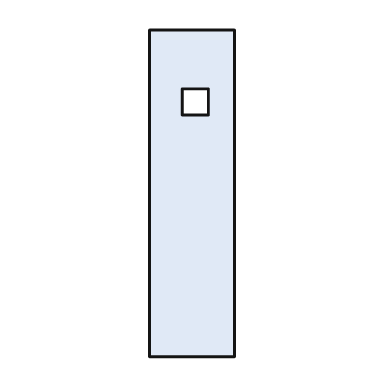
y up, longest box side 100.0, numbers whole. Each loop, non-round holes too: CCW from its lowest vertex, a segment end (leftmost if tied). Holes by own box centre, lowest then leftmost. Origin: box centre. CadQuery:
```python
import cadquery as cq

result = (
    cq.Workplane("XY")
    .moveTo(-13.0, -50.0)
    .lineTo(13.0, -50.0)
    .lineTo(13.0, 50.0)
    .lineTo(-13.0, 50.0)
    .close()
    .moveTo(-3.0, 24.0)
    .lineTo(5.0, 24.0)
    .lineTo(5.0, 32.0)
    .lineTo(-3.0, 32.0)
    .close()
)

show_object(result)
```